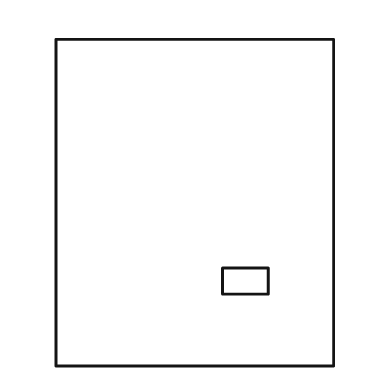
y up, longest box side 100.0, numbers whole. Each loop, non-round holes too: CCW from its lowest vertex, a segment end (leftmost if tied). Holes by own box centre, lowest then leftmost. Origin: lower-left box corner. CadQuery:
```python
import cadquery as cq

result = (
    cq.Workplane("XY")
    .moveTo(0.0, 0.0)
    .lineTo(85.0, 0.0)
    .lineTo(85.0, 100.0)
    .lineTo(0.0, 100.0)
    .close()
    .moveTo(51.0, 22.0)
    .lineTo(65.0, 22.0)
    .lineTo(65.0, 30.0)
    .lineTo(51.0, 30.0)
    .close()
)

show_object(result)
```